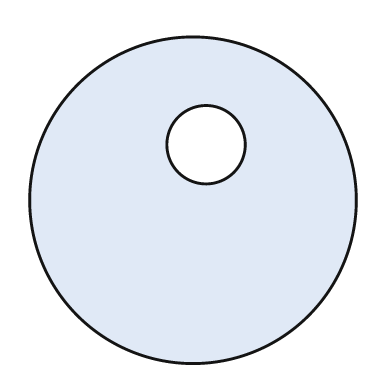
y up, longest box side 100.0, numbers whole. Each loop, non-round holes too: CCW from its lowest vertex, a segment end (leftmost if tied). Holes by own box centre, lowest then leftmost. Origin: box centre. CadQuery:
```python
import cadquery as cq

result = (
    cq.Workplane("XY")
    .moveTo(0.0, 0.0)
    .circle(50.0)
    .moveTo(4.0, 17.0)
    .circle(12.0)
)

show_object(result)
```